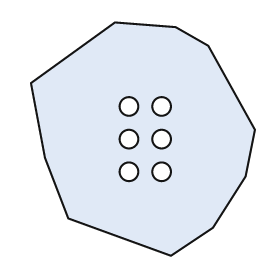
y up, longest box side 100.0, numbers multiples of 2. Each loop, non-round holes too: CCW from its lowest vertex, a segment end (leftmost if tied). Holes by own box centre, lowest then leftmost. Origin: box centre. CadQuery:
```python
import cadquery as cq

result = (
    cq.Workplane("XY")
    .moveTo(12.0, -50.0)
    .lineTo(30.0, -38.0)
    .lineTo(44.0, -16.0)
    .lineTo(48.0, 4.0)
    .lineTo(28.0, 40.0)
    .lineTo(14.0, 48.0)
    .lineTo(-12.0, 50.0)
    .lineTo(-48.0, 24.0)
    .lineTo(-42.0, -8.0)
    .lineTo(-32.0, -34.0)
    .close()
    .moveTo(-6.0, -14.0)
    .circle(4.0)
    .moveTo(8.0, -14.0)
    .circle(4.0)
    .moveTo(-6.0, 0.0)
    .circle(4.0)
    .moveTo(8.0, 0.0)
    .circle(4.0)
    .moveTo(-6.0, 14.0)
    .circle(4.0)
    .moveTo(8.0, 14.0)
    .circle(4.0)
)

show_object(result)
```